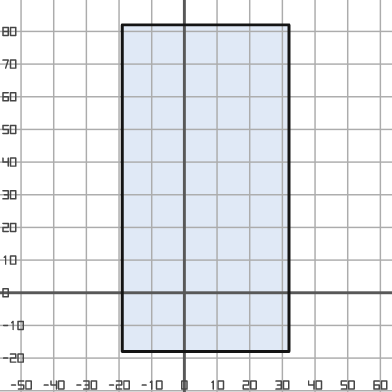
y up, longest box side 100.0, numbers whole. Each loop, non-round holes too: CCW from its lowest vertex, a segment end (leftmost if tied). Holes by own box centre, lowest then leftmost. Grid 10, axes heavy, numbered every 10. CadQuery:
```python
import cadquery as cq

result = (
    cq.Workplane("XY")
    .moveTo(-19.0, -18.0)
    .lineTo(32.0, -18.0)
    .lineTo(32.0, 82.0)
    .lineTo(-19.0, 82.0)
    .close()
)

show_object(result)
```